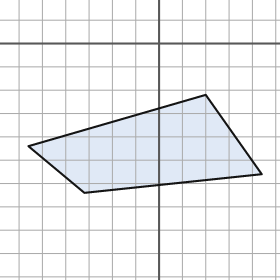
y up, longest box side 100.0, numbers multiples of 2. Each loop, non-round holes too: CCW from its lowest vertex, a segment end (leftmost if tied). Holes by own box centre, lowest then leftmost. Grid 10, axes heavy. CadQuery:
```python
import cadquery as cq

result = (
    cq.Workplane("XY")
    .moveTo(-32.0, -64.0)
    .lineTo(44.0, -56.0)
    .lineTo(20.0, -22.0)
    .lineTo(-56.0, -44.0)
    .close()
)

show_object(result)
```